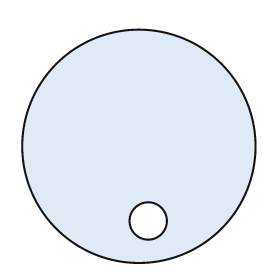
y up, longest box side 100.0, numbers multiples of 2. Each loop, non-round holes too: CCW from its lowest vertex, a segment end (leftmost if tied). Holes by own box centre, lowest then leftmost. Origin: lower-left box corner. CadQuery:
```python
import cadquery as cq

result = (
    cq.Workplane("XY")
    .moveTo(50.0, 50.0)
    .circle(50.0)
    .moveTo(54.0, 18.0)
    .circle(8.0)
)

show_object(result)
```